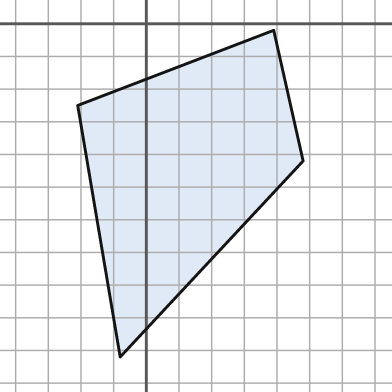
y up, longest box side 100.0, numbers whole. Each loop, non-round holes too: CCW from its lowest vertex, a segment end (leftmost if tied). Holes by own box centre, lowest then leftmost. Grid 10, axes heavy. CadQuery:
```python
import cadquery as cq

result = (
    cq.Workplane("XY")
    .moveTo(-8.0, -102.0)
    .lineTo(48.0, -42.0)
    .lineTo(39.0, -2.0)
    .lineTo(-21.0, -25.0)
    .close()
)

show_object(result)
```